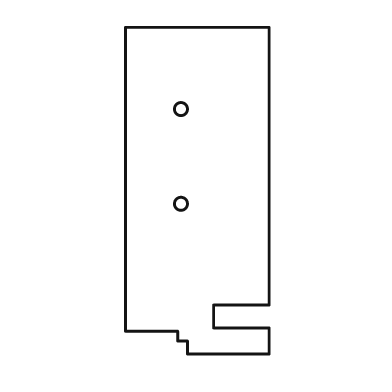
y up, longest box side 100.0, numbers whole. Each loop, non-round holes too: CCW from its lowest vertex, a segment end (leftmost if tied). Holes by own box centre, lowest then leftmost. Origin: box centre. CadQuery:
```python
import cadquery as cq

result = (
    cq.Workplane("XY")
    .moveTo(-3.0, -50.0)
    .lineTo(22.0, -50.0)
    .lineTo(22.0, -42.0)
    .lineTo(5.0, -42.0)
    .lineTo(5.0, -35.0)
    .lineTo(22.0, -35.0)
    .lineTo(22.0, 50.0)
    .lineTo(-22.0, 50.0)
    .lineTo(-22.0, -43.0)
    .lineTo(-6.0, -43.0)
    .lineTo(-6.0, -46.0)
    .lineTo(-3.0, -46.0)
    .close()
    .moveTo(-5.0, -4.0)
    .circle(2.0)
    .moveTo(-5.0, 25.0)
    .circle(2.0)
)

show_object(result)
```